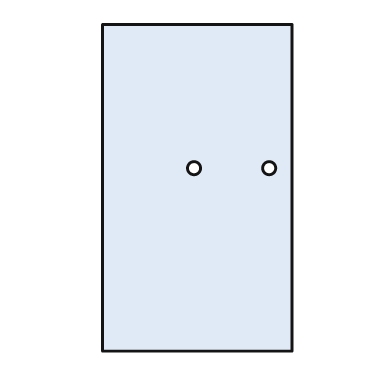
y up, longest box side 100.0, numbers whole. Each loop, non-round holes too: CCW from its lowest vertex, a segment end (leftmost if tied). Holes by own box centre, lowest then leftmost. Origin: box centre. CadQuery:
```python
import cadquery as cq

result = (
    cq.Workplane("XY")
    .moveTo(-29.0, -50.0)
    .lineTo(29.0, -50.0)
    .lineTo(29.0, 50.0)
    .lineTo(-29.0, 50.0)
    .close()
    .moveTo(-1.0, 6.0)
    .circle(2.0)
    .moveTo(22.0, 6.0)
    .circle(2.0)
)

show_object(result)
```